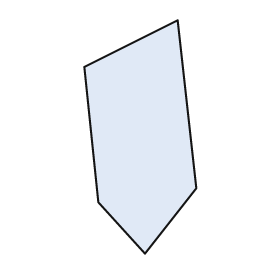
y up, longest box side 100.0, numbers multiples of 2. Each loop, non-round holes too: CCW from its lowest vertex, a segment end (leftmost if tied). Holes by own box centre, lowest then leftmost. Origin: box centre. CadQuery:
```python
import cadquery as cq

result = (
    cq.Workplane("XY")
    .moveTo(2.0, -50.0)
    .lineTo(24.0, -22.0)
    .lineTo(16.0, 50.0)
    .lineTo(-24.0, 30.0)
    .lineTo(-18.0, -28.0)
    .close()
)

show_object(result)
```